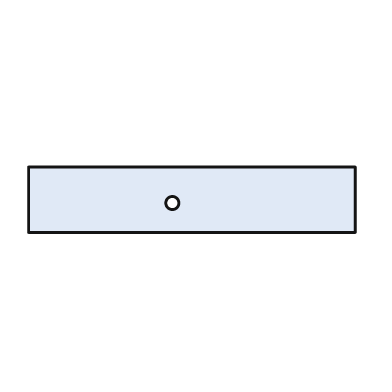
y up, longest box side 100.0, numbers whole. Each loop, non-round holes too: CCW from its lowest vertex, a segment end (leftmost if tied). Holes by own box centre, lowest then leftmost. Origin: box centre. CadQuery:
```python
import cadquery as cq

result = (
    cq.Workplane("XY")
    .moveTo(-50.0, -10.0)
    .lineTo(50.0, -10.0)
    .lineTo(50.0, 10.0)
    .lineTo(-50.0, 10.0)
    .close()
    .moveTo(-6.0, -1.0)
    .circle(2.0)
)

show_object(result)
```